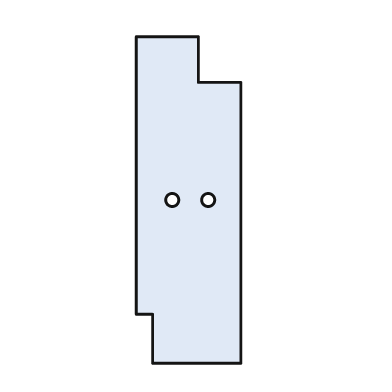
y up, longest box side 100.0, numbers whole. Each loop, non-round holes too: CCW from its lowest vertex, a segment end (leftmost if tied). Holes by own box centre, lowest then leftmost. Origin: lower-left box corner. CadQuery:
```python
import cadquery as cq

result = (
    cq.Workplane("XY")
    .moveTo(5.0, 0.0)
    .lineTo(32.0, 0.0)
    .lineTo(32.0, 86.0)
    .lineTo(19.0, 86.0)
    .lineTo(19.0, 100.0)
    .lineTo(0.0, 100.0)
    .lineTo(0.0, 15.0)
    .lineTo(5.0, 15.0)
    .close()
    .moveTo(11.0, 50.0)
    .circle(2.0)
    .moveTo(22.0, 50.0)
    .circle(2.0)
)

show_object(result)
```